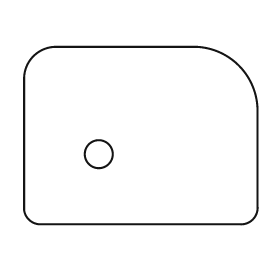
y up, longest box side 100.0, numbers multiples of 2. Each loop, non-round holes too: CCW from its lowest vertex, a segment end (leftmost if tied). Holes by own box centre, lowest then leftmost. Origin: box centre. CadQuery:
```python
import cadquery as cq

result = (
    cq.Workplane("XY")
    .moveTo(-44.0, -38.0)
    .lineTo(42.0, -38.0)
    .threePointArc((48.0, -36.0), (50.0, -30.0))
    .lineTo(50.0, 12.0)
    .threePointArc((42.0, 30.0), (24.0, 38.0))
    .lineTo(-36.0, 38.0)
    .threePointArc((-46.0, 34.0), (-50.0, 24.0))
    .lineTo(-50.0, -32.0)
    .threePointArc((-48.0, -36.0), (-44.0, -38.0))
    .close()
    .moveTo(-18.0, -8.0)
    .circle(6.0)
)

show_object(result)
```